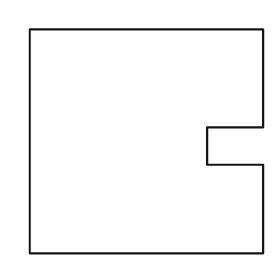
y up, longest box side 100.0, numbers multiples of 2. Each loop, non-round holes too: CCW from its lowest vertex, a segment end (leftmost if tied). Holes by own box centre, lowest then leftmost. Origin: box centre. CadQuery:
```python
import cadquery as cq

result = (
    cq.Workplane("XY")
    .moveTo(-50.0, -48.0)
    .lineTo(50.0, -48.0)
    .lineTo(50.0, -10.0)
    .lineTo(26.0, -10.0)
    .lineTo(26.0, 6.0)
    .lineTo(50.0, 6.0)
    .lineTo(50.0, 48.0)
    .lineTo(-50.0, 48.0)
    .close()
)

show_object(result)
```